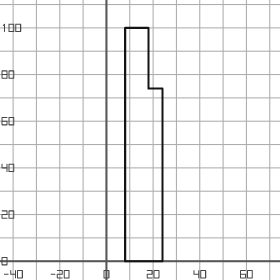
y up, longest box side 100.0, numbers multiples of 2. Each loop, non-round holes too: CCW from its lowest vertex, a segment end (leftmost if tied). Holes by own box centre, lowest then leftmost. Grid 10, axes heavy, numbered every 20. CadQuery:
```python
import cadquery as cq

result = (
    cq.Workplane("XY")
    .moveTo(8.0, 0.0)
    .lineTo(24.0, 0.0)
    .lineTo(24.0, 74.0)
    .lineTo(18.0, 74.0)
    .lineTo(18.0, 100.0)
    .lineTo(8.0, 100.0)
    .close()
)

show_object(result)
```